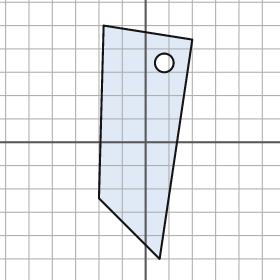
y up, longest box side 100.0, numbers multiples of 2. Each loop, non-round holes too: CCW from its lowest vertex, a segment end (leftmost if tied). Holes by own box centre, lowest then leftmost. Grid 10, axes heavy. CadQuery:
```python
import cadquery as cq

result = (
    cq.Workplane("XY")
    .moveTo(6.0, -50.0)
    .lineTo(20.0, 44.0)
    .lineTo(-18.0, 50.0)
    .lineTo(-20.0, -24.0)
    .close()
    .moveTo(8.0, 34.0)
    .circle(4.0)
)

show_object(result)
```